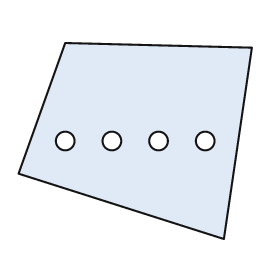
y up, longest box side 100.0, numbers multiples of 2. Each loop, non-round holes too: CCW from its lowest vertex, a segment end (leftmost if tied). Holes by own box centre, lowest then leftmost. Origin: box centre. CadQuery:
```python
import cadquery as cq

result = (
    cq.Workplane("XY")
    .moveTo(38.0, -42.0)
    .lineTo(50.0, 40.0)
    .lineTo(-30.0, 42.0)
    .lineTo(-50.0, -14.0)
    .close()
    .moveTo(-30.0, 0.0)
    .circle(4.0)
    .moveTo(-10.0, 0.0)
    .circle(4.0)
    .moveTo(10.0, 0.0)
    .circle(4.0)
    .moveTo(30.0, 0.0)
    .circle(4.0)
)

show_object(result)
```